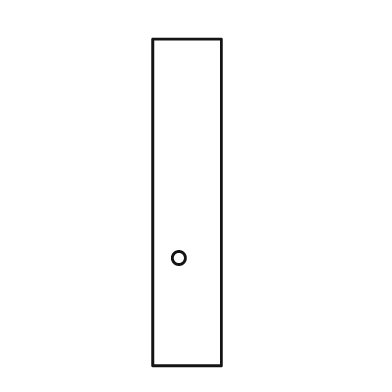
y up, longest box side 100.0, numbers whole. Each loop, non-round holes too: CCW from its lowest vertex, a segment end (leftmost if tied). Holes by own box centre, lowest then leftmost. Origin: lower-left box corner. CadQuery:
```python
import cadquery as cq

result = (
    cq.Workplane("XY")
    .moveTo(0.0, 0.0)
    .lineTo(21.0, 0.0)
    .lineTo(21.0, 100.0)
    .lineTo(0.0, 100.0)
    .close()
    .moveTo(8.0, 33.0)
    .circle(2.0)
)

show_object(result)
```